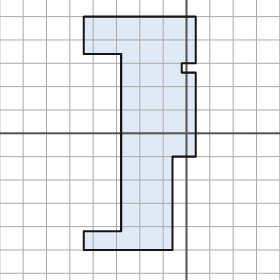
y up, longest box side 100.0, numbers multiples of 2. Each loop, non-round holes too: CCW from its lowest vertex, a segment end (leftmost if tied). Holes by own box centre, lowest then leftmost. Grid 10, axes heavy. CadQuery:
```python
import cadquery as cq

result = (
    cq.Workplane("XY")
    .moveTo(-44.0, -50.0)
    .lineTo(-6.0, -50.0)
    .lineTo(-6.0, -10.0)
    .lineTo(4.0, -10.0)
    .lineTo(4.0, 26.0)
    .lineTo(-2.0, 26.0)
    .lineTo(-2.0, 30.0)
    .lineTo(4.0, 30.0)
    .lineTo(4.0, 50.0)
    .lineTo(-44.0, 50.0)
    .lineTo(-44.0, 34.0)
    .lineTo(-28.0, 34.0)
    .lineTo(-28.0, -42.0)
    .lineTo(-44.0, -42.0)
    .close()
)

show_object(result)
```